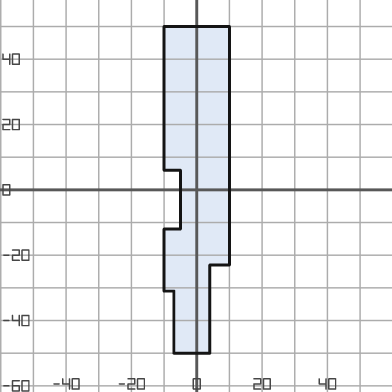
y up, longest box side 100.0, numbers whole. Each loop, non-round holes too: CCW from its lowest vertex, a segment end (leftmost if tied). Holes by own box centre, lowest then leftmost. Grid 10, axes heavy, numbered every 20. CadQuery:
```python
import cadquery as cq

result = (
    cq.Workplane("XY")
    .moveTo(-7.0, -50.0)
    .lineTo(4.0, -50.0)
    .lineTo(4.0, -23.0)
    .lineTo(10.0, -23.0)
    .lineTo(10.0, 50.0)
    .lineTo(-10.0, 50.0)
    .lineTo(-10.0, 6.0)
    .lineTo(-5.0, 6.0)
    .lineTo(-5.0, -12.0)
    .lineTo(-10.0, -12.0)
    .lineTo(-10.0, -31.0)
    .lineTo(-7.0, -31.0)
    .close()
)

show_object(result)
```